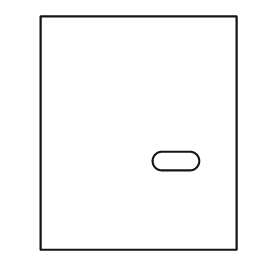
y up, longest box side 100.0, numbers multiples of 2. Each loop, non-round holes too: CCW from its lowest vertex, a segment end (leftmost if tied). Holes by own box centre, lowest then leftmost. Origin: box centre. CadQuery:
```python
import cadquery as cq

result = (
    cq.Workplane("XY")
    .moveTo(-42.0, -50.0)
    .lineTo(42.0, -50.0)
    .lineTo(42.0, 50.0)
    .lineTo(-42.0, 50.0)
    .close()
    .moveTo(10.0, -16.0)
    .lineTo(22.0, -16.0)
    .threePointArc((26.0, -12.0), (22.0, -8.0))
    .lineTo(10.0, -8.0)
    .threePointArc((6.0, -12.0), (10.0, -16.0))
    .close()
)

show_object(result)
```